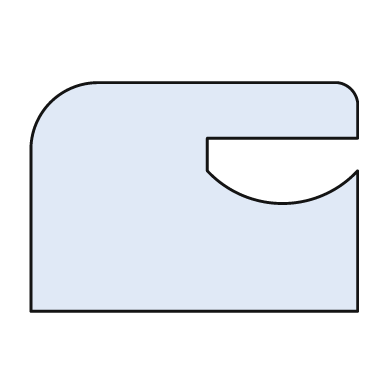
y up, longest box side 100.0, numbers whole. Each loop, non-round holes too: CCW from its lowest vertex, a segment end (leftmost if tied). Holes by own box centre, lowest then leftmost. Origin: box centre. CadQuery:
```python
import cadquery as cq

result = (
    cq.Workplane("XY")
    .moveTo(-50.0, -35.0)
    .lineTo(50.0, -35.0)
    .lineTo(50.0, 8.0)
    .threePointArc((27.0, -2.0), (4.0, 8.0))
    .lineTo(4.0, 18.0)
    .lineTo(50.0, 18.0)
    .lineTo(50.0, 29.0)
    .threePointArc((48.0, 33.0), (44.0, 35.0))
    .lineTo(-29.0, 35.0)
    .threePointArc((-44.0, 29.0), (-50.0, 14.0))
    .close()
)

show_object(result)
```